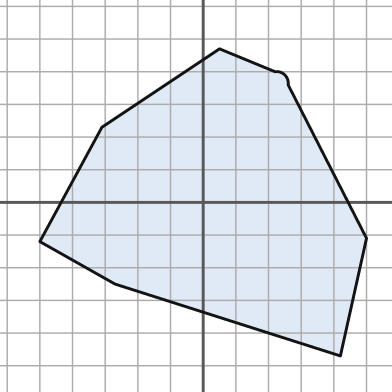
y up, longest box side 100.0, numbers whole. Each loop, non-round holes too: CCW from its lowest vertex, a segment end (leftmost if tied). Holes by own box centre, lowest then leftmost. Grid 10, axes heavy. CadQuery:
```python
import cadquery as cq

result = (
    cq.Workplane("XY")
    .moveTo(42.0, -47.0)
    .lineTo(50.0, -11.0)
    .lineTo(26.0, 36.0)
    .threePointArc((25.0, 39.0), (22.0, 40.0))
    .lineTo(5.0, 47.0)
    .lineTo(-31.0, 23.0)
    .lineTo(-50.0, -12.0)
    .lineTo(-27.0, -25.0)
    .close()
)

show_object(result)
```